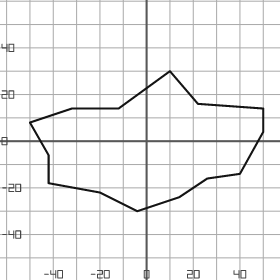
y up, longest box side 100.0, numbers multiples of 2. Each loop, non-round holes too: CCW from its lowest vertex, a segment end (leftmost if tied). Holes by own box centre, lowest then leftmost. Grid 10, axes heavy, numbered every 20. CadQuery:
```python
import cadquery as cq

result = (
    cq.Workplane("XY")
    .moveTo(-4.0, -30.0)
    .lineTo(14.0, -24.0)
    .lineTo(26.0, -16.0)
    .lineTo(40.0, -14.0)
    .lineTo(50.0, 4.0)
    .lineTo(50.0, 14.0)
    .lineTo(22.0, 16.0)
    .lineTo(10.0, 30.0)
    .lineTo(-12.0, 14.0)
    .lineTo(-32.0, 14.0)
    .lineTo(-50.0, 8.0)
    .lineTo(-42.0, -6.0)
    .lineTo(-42.0, -18.0)
    .lineTo(-20.0, -22.0)
    .close()
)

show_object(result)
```